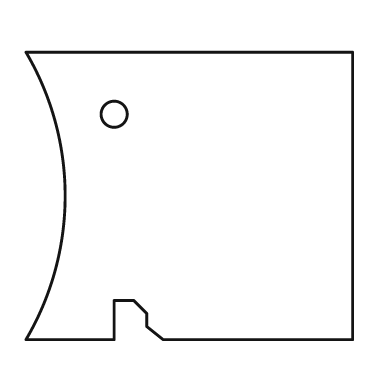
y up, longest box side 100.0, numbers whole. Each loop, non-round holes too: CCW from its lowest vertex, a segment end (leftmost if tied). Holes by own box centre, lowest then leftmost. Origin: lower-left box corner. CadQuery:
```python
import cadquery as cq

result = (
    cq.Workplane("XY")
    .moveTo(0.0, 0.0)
    .lineTo(27.0, 0.0)
    .lineTo(27.0, 12.0)
    .lineTo(33.0, 12.0)
    .lineTo(37.0, 8.0)
    .lineTo(37.0, 4.0)
    .lineTo(42.0, 0.0)
    .lineTo(100.0, 0.0)
    .lineTo(100.0, 88.0)
    .lineTo(0.0, 88.0)
    .threePointArc((12.0, 44.0), (0.0, 0.0))
    .close()
    .moveTo(27.0, 69.0)
    .circle(4.0)
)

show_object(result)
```